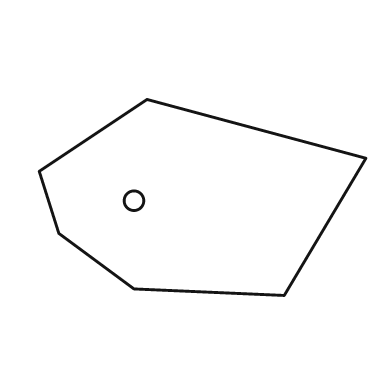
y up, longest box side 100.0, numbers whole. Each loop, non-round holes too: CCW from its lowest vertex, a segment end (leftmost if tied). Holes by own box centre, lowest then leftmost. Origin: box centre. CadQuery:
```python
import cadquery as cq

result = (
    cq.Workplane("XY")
    .moveTo(25.0, -30.0)
    .lineTo(50.0, 12.0)
    .lineTo(-17.0, 30.0)
    .lineTo(-50.0, 8.0)
    .lineTo(-44.0, -11.0)
    .lineTo(-21.0, -28.0)
    .close()
    .moveTo(-21.0, -1.0)
    .circle(3.0)
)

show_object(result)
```